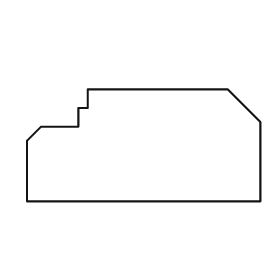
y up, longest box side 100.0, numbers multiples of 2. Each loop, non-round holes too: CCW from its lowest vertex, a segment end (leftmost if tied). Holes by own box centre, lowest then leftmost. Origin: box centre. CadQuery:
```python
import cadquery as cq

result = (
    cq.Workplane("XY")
    .moveTo(-50.0, -24.0)
    .lineTo(50.0, -24.0)
    .lineTo(50.0, 10.0)
    .lineTo(36.0, 24.0)
    .lineTo(-24.0, 24.0)
    .lineTo(-24.0, 16.0)
    .lineTo(-28.0, 16.0)
    .lineTo(-28.0, 8.0)
    .lineTo(-44.0, 8.0)
    .lineTo(-50.0, 2.0)
    .close()
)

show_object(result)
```